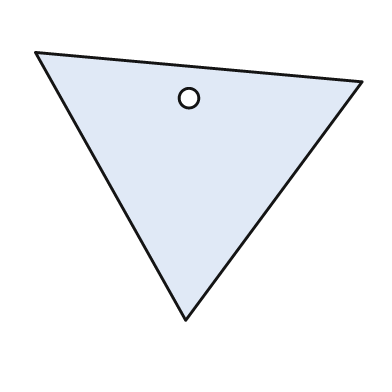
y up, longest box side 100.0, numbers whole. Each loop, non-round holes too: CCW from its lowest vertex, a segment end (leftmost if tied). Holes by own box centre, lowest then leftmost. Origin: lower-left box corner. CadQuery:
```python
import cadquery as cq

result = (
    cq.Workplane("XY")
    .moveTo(46.0, 0.0)
    .lineTo(100.0, 73.0)
    .lineTo(0.0, 82.0)
    .close()
    .moveTo(47.0, 68.0)
    .circle(3.0)
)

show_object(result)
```